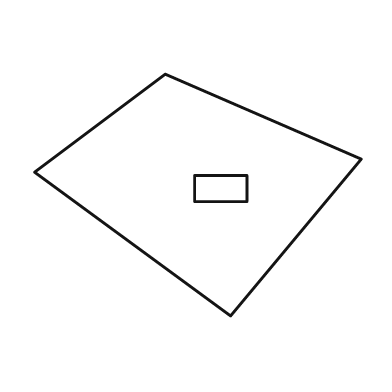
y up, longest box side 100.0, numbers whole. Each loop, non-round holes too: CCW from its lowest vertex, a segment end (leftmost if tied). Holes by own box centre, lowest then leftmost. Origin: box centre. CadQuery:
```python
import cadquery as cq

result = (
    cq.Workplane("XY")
    .moveTo(10.0, -37.0)
    .lineTo(50.0, 11.0)
    .lineTo(-10.0, 37.0)
    .lineTo(-50.0, 7.0)
    .close()
    .moveTo(-1.0, -2.0)
    .lineTo(15.0, -2.0)
    .lineTo(15.0, 6.0)
    .lineTo(-1.0, 6.0)
    .close()
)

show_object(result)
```